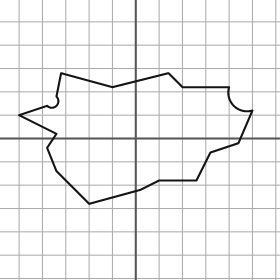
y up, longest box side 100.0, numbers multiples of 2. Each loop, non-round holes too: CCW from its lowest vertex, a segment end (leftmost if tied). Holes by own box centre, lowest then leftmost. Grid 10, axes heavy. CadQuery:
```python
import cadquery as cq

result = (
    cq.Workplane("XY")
    .moveTo(-20.0, -28.0)
    .lineTo(2.0, -22.0)
    .lineTo(10.0, -18.0)
    .lineTo(26.0, -18.0)
    .lineTo(32.0, -6.0)
    .lineTo(44.0, -2.0)
    .lineTo(50.0, 12.0)
    .threePointArc((42.0, 14.0), (40.0, 22.0))
    .lineTo(20.0, 22.0)
    .lineTo(14.0, 28.0)
    .lineTo(-10.0, 22.0)
    .lineTo(-32.0, 28.0)
    .lineTo(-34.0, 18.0)
    .threePointArc((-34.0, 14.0), (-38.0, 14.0))
    .lineTo(-50.0, 10.0)
    .lineTo(-34.0, 2.0)
    .lineTo(-38.0, -4.0)
    .lineTo(-34.0, -14.0)
    .close()
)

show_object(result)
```